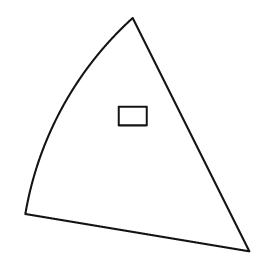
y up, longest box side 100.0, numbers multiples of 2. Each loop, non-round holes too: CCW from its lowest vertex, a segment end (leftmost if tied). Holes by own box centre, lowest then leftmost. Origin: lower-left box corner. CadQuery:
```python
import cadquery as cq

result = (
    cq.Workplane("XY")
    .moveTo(96.0, 0.0)
    .lineTo(46.0, 100.0)
    .threePointArc((16.0, 62.0), (0.0, 16.0))
    .close()
    .moveTo(40.0, 54.0)
    .lineTo(52.0, 54.0)
    .lineTo(52.0, 62.0)
    .lineTo(40.0, 62.0)
    .close()
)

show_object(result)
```